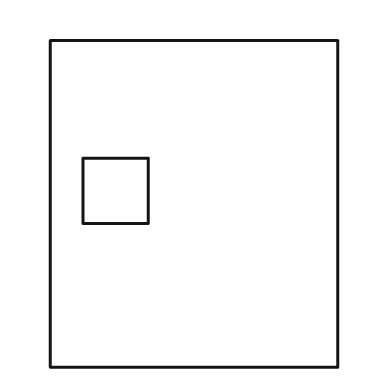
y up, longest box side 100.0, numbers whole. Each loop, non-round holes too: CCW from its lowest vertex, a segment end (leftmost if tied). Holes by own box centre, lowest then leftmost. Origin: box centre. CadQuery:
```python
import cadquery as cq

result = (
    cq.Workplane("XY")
    .moveTo(-44.0, -50.0)
    .lineTo(44.0, -50.0)
    .lineTo(44.0, 50.0)
    .lineTo(-44.0, 50.0)
    .close()
    .moveTo(-34.0, -6.0)
    .lineTo(-14.0, -6.0)
    .lineTo(-14.0, 14.0)
    .lineTo(-34.0, 14.0)
    .close()
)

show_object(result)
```